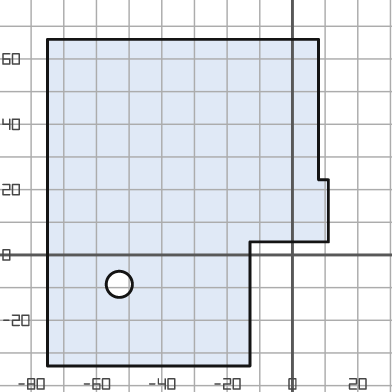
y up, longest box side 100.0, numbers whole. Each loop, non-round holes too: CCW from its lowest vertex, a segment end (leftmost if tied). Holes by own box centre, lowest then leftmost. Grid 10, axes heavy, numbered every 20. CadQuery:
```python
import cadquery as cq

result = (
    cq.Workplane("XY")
    .moveTo(-75.0, -34.0)
    .lineTo(-13.0, -34.0)
    .lineTo(-13.0, 4.0)
    .lineTo(11.0, 4.0)
    .lineTo(11.0, 23.0)
    .lineTo(8.0, 23.0)
    .lineTo(8.0, 66.0)
    .lineTo(-75.0, 66.0)
    .close()
    .moveTo(-53.0, -9.0)
    .circle(4.0)
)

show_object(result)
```